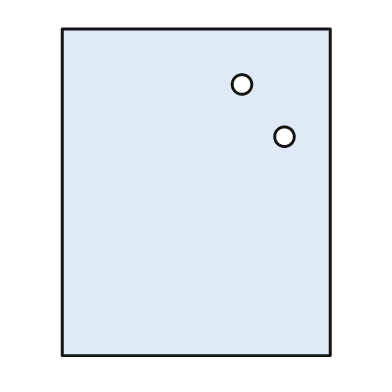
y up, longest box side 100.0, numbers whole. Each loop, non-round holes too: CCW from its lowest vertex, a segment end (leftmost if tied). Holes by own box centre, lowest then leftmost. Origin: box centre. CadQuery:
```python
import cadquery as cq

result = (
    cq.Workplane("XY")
    .moveTo(-41.0, -50.0)
    .lineTo(41.0, -50.0)
    .lineTo(41.0, 50.0)
    .lineTo(-41.0, 50.0)
    .close()
    .moveTo(27.0, 17.0)
    .circle(3.0)
    .moveTo(14.0, 33.0)
    .circle(3.0)
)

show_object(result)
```